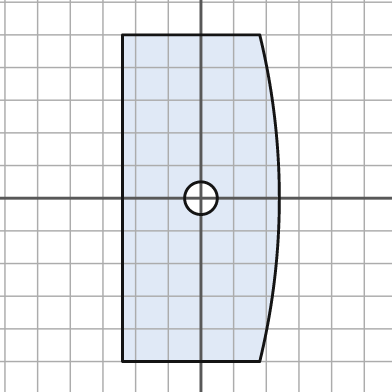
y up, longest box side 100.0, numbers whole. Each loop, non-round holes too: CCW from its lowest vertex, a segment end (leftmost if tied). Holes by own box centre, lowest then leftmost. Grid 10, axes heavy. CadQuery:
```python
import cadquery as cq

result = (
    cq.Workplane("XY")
    .moveTo(-24.0, -50.0)
    .lineTo(18.0, -50.0)
    .threePointArc((24.0, 0.0), (18.0, 50.0))
    .lineTo(-24.0, 50.0)
    .close()
    .moveTo(0.0, 0.0)
    .circle(5.0)
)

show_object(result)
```